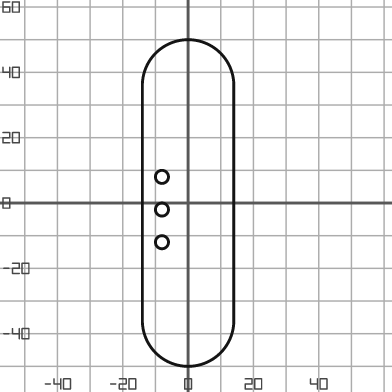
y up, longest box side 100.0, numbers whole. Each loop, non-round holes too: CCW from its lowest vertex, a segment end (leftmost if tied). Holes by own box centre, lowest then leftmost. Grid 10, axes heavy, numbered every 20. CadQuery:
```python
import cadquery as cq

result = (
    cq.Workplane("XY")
    .moveTo(-14.0, -36.0)
    .threePointArc((0.0, -50.0), (14.0, -36.0))
    .lineTo(14.0, 36.0)
    .threePointArc((0.0, 50.0), (-14.0, 36.0))
    .close()
    .moveTo(-8.0, -12.0)
    .circle(2.0)
    .moveTo(-8.0, -2.0)
    .circle(2.0)
    .moveTo(-8.0, 8.0)
    .circle(2.0)
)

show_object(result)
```